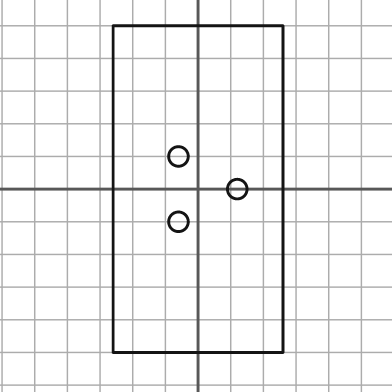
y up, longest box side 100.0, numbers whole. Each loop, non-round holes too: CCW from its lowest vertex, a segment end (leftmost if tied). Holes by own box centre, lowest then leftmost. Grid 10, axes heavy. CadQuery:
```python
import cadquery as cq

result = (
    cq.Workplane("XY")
    .moveTo(-26.0, -50.0)
    .lineTo(26.0, -50.0)
    .lineTo(26.0, 50.0)
    .lineTo(-26.0, 50.0)
    .close()
    .moveTo(-6.0, -10.0)
    .circle(3.0)
    .moveTo(12.0, 0.0)
    .circle(3.0)
    .moveTo(-6.0, 10.0)
    .circle(3.0)
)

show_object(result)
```